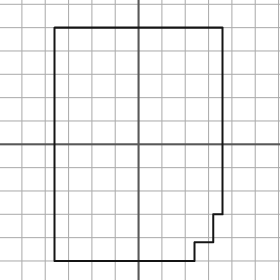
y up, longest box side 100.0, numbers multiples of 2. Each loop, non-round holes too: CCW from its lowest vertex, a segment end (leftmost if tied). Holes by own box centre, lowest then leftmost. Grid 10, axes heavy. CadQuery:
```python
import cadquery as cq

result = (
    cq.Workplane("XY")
    .moveTo(-36.0, -50.0)
    .lineTo(24.0, -50.0)
    .lineTo(24.0, -42.0)
    .lineTo(32.0, -42.0)
    .lineTo(32.0, -30.0)
    .lineTo(36.0, -30.0)
    .lineTo(36.0, 50.0)
    .lineTo(-36.0, 50.0)
    .close()
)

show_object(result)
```